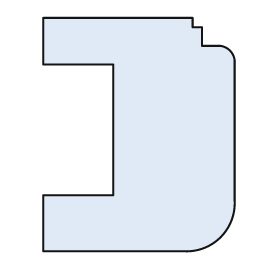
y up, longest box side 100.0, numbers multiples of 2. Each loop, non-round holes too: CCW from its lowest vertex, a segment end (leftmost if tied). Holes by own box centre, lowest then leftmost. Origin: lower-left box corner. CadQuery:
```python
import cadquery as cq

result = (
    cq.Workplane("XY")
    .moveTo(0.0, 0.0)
    .lineTo(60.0, 0.0)
    .threePointArc((76.0, 6.0), (82.0, 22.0))
    .lineTo(82.0, 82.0)
    .threePointArc((80.0, 86.0), (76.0, 88.0))
    .lineTo(68.0, 88.0)
    .lineTo(68.0, 96.0)
    .lineTo(64.0, 96.0)
    .lineTo(64.0, 100.0)
    .lineTo(0.0, 100.0)
    .lineTo(0.0, 80.0)
    .lineTo(30.0, 80.0)
    .lineTo(30.0, 24.0)
    .lineTo(0.0, 24.0)
    .close()
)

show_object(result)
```